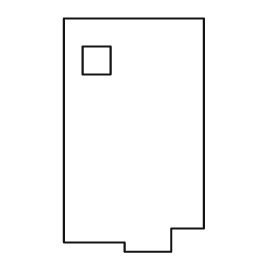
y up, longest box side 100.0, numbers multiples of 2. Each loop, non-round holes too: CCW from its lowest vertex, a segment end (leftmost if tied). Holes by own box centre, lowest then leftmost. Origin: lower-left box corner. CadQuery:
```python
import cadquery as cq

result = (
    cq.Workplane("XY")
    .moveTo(26.0, 0.0)
    .lineTo(46.0, 0.0)
    .lineTo(46.0, 10.0)
    .lineTo(60.0, 10.0)
    .lineTo(60.0, 100.0)
    .lineTo(0.0, 100.0)
    .lineTo(0.0, 4.0)
    .lineTo(26.0, 4.0)
    .close()
    .moveTo(8.0, 76.0)
    .lineTo(20.0, 76.0)
    .lineTo(20.0, 88.0)
    .lineTo(8.0, 88.0)
    .close()
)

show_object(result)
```